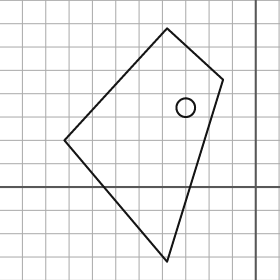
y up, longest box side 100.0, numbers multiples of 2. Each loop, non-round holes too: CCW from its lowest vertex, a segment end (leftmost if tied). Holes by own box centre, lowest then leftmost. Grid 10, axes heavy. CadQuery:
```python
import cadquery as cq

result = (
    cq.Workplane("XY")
    .moveTo(-38.0, -32.0)
    .lineTo(-14.0, 46.0)
    .lineTo(-38.0, 68.0)
    .lineTo(-82.0, 20.0)
    .close()
    .moveTo(-30.0, 34.0)
    .circle(4.0)
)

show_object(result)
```